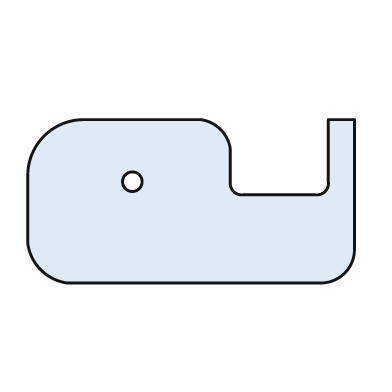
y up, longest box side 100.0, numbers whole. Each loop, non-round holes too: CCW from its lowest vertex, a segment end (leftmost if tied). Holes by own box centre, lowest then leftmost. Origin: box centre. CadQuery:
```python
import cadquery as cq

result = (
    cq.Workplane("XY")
    .moveTo(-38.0, -25.0)
    .lineTo(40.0, -25.0)
    .threePointArc((47.0, -22.0), (50.0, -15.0))
    .lineTo(50.0, 25.0)
    .lineTo(42.0, 25.0)
    .lineTo(42.0, 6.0)
    .threePointArc((41.0, 3.0), (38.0, 2.0))
    .lineTo(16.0, 2.0)
    .threePointArc((13.0, 3.0), (12.0, 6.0))
    .lineTo(12.0, 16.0)
    .threePointArc((9.0, 22.0), (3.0, 25.0))
    .lineTo(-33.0, 25.0)
    .threePointArc((-45.0, 20.0), (-50.0, 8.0))
    .lineTo(-50.0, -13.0)
    .threePointArc((-46.0, -21.0), (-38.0, -25.0))
    .close()
    .moveTo(-18.0, 6.0)
    .circle(3.0)
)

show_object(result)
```